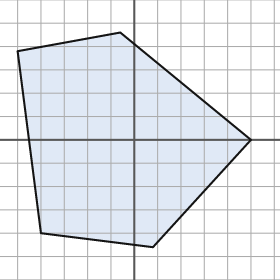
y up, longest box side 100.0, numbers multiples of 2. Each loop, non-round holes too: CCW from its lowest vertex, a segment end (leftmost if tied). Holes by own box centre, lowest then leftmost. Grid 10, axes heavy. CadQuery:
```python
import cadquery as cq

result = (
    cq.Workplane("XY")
    .moveTo(8.0, -46.0)
    .lineTo(50.0, 0.0)
    .lineTo(-6.0, 46.0)
    .lineTo(-50.0, 38.0)
    .lineTo(-40.0, -40.0)
    .close()
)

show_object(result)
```